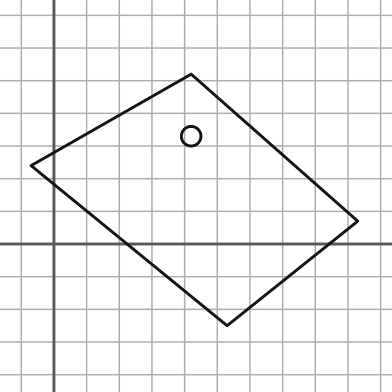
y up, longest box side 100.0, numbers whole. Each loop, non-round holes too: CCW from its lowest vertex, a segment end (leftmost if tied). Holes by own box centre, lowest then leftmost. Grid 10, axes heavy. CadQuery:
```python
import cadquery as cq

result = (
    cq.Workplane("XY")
    .moveTo(53.0, -25.0)
    .lineTo(93.0, 7.0)
    .lineTo(42.0, 52.0)
    .lineTo(-7.0, 24.0)
    .close()
    .moveTo(42.0, 33.0)
    .circle(3.0)
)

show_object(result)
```